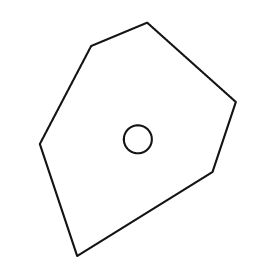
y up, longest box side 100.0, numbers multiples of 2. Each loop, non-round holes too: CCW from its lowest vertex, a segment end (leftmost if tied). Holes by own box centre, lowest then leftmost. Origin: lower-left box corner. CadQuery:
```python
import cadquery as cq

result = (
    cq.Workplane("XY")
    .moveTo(16.0, 0.0)
    .lineTo(74.0, 36.0)
    .lineTo(84.0, 66.0)
    .lineTo(46.0, 100.0)
    .lineTo(22.0, 90.0)
    .lineTo(0.0, 48.0)
    .close()
    .moveTo(42.0, 50.0)
    .circle(6.0)
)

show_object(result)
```